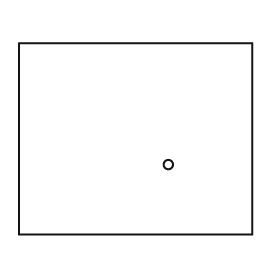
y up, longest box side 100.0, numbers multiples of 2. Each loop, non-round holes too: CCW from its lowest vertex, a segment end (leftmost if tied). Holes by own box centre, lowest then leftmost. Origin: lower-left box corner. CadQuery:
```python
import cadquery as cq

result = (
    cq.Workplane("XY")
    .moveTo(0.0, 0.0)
    .lineTo(100.0, 0.0)
    .lineTo(100.0, 82.0)
    .lineTo(0.0, 82.0)
    .close()
    .moveTo(64.0, 30.0)
    .circle(2.0)
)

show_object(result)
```